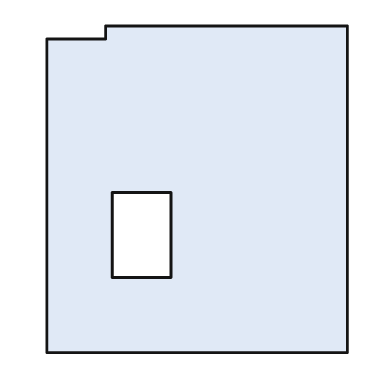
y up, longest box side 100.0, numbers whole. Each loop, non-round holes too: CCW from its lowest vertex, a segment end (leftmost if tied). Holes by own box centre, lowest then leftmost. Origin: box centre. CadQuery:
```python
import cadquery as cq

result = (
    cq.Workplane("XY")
    .moveTo(-46.0, -50.0)
    .lineTo(46.0, -50.0)
    .lineTo(46.0, 50.0)
    .lineTo(-28.0, 50.0)
    .lineTo(-28.0, 46.0)
    .lineTo(-46.0, 46.0)
    .close()
    .moveTo(-26.0, -27.0)
    .lineTo(-8.0, -27.0)
    .lineTo(-8.0, -1.0)
    .lineTo(-26.0, -1.0)
    .close()
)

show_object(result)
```